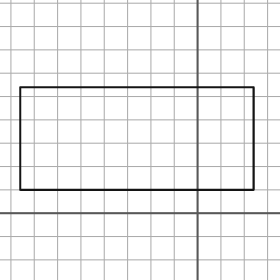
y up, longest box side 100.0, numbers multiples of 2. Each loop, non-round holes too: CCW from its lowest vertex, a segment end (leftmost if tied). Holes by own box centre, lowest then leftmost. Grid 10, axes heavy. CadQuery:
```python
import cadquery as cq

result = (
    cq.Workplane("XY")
    .moveTo(-76.0, 10.0)
    .lineTo(24.0, 10.0)
    .lineTo(24.0, 54.0)
    .lineTo(-76.0, 54.0)
    .close()
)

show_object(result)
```